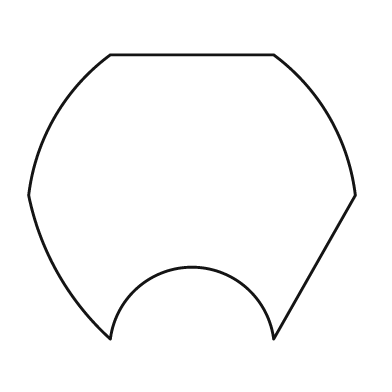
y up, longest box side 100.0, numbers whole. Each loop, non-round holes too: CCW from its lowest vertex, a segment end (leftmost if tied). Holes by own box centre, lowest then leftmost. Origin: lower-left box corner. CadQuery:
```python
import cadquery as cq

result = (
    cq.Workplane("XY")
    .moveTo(25.0, 0.0)
    .threePointArc((50.0, 22.0), (75.0, 0.0))
    .lineTo(100.0, 44.0)
    .threePointArc((92.0, 68.0), (75.0, 87.0))
    .lineTo(25.0, 87.0)
    .threePointArc((8.0, 68.0), (0.0, 44.0))
    .threePointArc((9.0, 20.0), (25.0, 0.0))
    .close()
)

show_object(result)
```